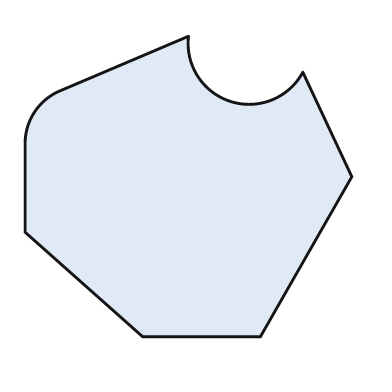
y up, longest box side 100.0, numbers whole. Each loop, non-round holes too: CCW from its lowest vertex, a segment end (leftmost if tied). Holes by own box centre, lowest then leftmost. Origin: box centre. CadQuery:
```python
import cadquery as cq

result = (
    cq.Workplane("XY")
    .moveTo(-14.0, -46.0)
    .lineTo(22.0, -46.0)
    .lineTo(50.0, 3.0)
    .lineTo(35.0, 35.0)
    .threePointArc((13.0, 26.0), (0.0, 46.0))
    .lineTo(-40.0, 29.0)
    .threePointArc((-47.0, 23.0), (-50.0, 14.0))
    .lineTo(-50.0, -14.0)
    .close()
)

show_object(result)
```